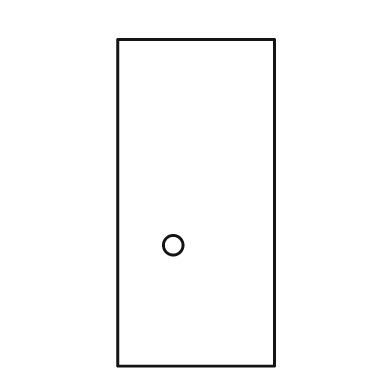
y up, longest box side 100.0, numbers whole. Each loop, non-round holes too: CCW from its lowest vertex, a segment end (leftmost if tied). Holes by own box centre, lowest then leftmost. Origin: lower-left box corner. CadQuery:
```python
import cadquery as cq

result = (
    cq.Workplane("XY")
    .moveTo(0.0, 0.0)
    .lineTo(48.0, 0.0)
    .lineTo(48.0, 100.0)
    .lineTo(0.0, 100.0)
    .close()
    .moveTo(17.0, 37.0)
    .circle(3.0)
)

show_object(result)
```